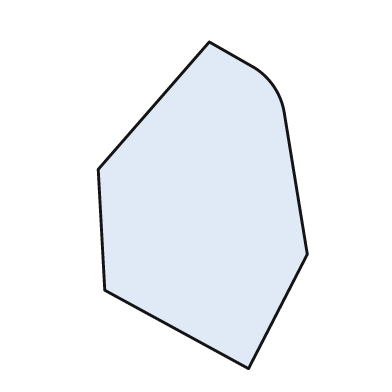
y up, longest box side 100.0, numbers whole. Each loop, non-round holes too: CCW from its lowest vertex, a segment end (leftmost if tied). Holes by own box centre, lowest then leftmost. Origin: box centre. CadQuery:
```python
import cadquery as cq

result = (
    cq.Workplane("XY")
    .moveTo(14.0, -50.0)
    .lineTo(32.0, -15.0)
    .lineTo(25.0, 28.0)
    .threePointArc((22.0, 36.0), (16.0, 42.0))
    .lineTo(2.0, 50.0)
    .lineTo(-32.0, 11.0)
    .lineTo(-30.0, -26.0)
    .close()
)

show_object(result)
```